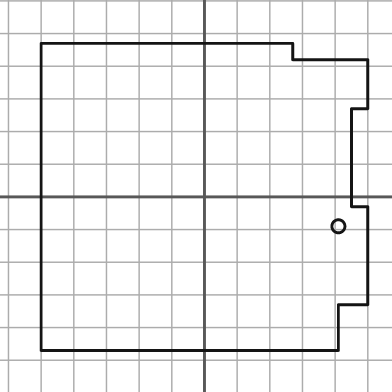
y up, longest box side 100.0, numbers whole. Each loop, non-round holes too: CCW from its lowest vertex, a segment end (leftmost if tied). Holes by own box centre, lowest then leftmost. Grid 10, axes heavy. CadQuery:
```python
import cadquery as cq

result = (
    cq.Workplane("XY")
    .moveTo(-50.0, -47.0)
    .lineTo(41.0, -47.0)
    .lineTo(41.0, -33.0)
    .lineTo(50.0, -33.0)
    .lineTo(50.0, -3.0)
    .lineTo(45.0, -3.0)
    .lineTo(45.0, 27.0)
    .lineTo(50.0, 27.0)
    .lineTo(50.0, 42.0)
    .lineTo(27.0, 42.0)
    .lineTo(27.0, 47.0)
    .lineTo(-50.0, 47.0)
    .close()
    .moveTo(41.0, -9.0)
    .circle(2.0)
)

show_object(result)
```